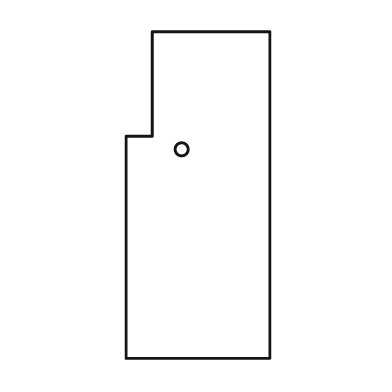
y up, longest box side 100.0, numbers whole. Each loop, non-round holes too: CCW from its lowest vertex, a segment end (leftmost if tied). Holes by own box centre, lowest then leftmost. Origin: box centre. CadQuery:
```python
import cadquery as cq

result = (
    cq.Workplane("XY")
    .moveTo(-22.0, -50.0)
    .lineTo(22.0, -50.0)
    .lineTo(22.0, 50.0)
    .lineTo(-14.0, 50.0)
    .lineTo(-14.0, 18.0)
    .lineTo(-22.0, 18.0)
    .close()
    .moveTo(-5.0, 14.0)
    .circle(2.0)
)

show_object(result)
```